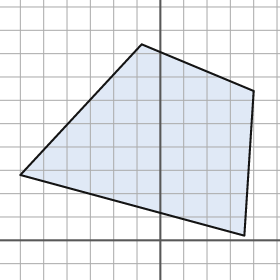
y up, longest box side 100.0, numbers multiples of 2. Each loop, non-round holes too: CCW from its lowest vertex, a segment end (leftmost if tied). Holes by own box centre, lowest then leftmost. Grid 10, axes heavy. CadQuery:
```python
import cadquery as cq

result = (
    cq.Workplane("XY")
    .moveTo(36.0, 2.0)
    .lineTo(40.0, 64.0)
    .lineTo(-8.0, 84.0)
    .lineTo(-60.0, 28.0)
    .close()
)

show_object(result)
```